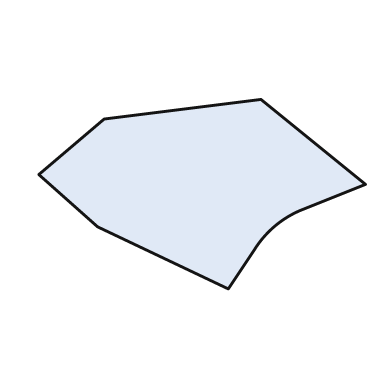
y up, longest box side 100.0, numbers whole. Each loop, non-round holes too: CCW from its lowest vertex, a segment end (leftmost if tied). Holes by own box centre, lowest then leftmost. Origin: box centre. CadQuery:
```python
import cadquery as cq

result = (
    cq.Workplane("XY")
    .moveTo(8.0, -29.0)
    .lineTo(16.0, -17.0)
    .threePointArc((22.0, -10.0), (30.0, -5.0))
    .lineTo(50.0, 3.0)
    .lineTo(18.0, 29.0)
    .lineTo(-30.0, 23.0)
    .lineTo(-50.0, 6.0)
    .lineTo(-32.0, -10.0)
    .close()
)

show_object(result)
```